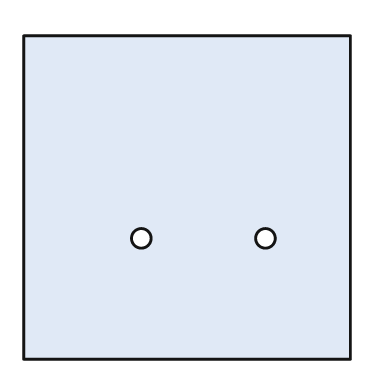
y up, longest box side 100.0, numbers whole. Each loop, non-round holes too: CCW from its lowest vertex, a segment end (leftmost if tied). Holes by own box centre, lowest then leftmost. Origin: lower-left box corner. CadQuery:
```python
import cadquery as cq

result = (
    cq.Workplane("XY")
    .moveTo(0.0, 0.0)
    .lineTo(100.0, 0.0)
    .lineTo(100.0, 99.0)
    .lineTo(0.0, 99.0)
    .close()
    .moveTo(36.0, 37.0)
    .circle(3.0)
    .moveTo(74.0, 37.0)
    .circle(3.0)
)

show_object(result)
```